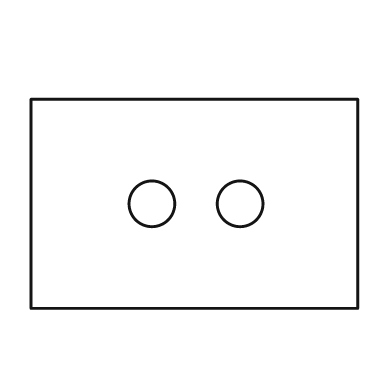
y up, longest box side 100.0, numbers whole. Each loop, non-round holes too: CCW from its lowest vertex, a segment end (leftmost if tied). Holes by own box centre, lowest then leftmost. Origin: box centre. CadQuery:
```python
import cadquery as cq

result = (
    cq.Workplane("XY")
    .moveTo(-50.0, -32.0)
    .lineTo(50.0, -32.0)
    .lineTo(50.0, 32.0)
    .lineTo(-50.0, 32.0)
    .close()
    .moveTo(-13.0, 0.0)
    .circle(7.0)
    .moveTo(14.0, 0.0)
    .circle(7.0)
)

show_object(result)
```